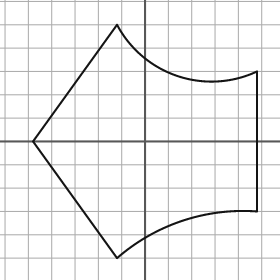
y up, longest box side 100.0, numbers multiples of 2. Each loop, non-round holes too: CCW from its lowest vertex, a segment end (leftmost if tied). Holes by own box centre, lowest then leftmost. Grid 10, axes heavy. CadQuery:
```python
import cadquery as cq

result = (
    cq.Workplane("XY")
    .moveTo(-12.0, -50.0)
    .threePointArc((16.0, -34.0), (48.0, -30.0))
    .lineTo(48.0, 30.0)
    .threePointArc((14.0, 28.0), (-12.0, 50.0))
    .lineTo(-48.0, 0.0)
    .close()
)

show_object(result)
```